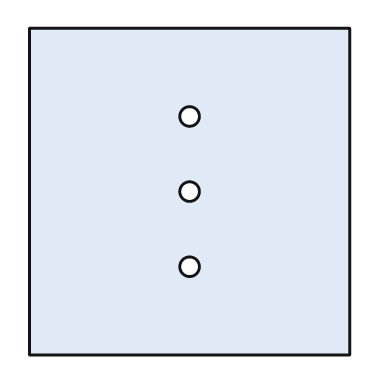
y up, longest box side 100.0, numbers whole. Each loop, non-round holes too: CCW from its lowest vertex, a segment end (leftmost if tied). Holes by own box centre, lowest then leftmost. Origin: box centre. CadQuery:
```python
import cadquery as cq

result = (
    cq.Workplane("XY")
    .moveTo(-49.0, -50.0)
    .lineTo(49.0, -50.0)
    .lineTo(49.0, 50.0)
    .lineTo(-49.0, 50.0)
    .close()
    .moveTo(0.0, -23.0)
    .circle(3.0)
    .moveTo(0.0, 0.0)
    .circle(3.0)
    .moveTo(0.0, 23.0)
    .circle(3.0)
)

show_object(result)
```